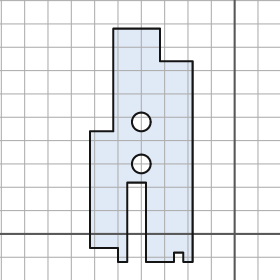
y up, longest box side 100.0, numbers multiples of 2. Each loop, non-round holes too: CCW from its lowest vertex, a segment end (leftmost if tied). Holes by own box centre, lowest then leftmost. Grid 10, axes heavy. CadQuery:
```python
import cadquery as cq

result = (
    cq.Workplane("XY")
    .moveTo(-50.0, -12.0)
    .lineTo(-46.0, -12.0)
    .lineTo(-46.0, 22.0)
    .lineTo(-38.0, 22.0)
    .lineTo(-38.0, -12.0)
    .lineTo(-26.0, -12.0)
    .lineTo(-26.0, -8.0)
    .lineTo(-22.0, -8.0)
    .lineTo(-22.0, -12.0)
    .lineTo(-18.0, -12.0)
    .lineTo(-18.0, 74.0)
    .lineTo(-32.0, 74.0)
    .lineTo(-32.0, 88.0)
    .lineTo(-52.0, 88.0)
    .lineTo(-52.0, 44.0)
    .lineTo(-62.0, 44.0)
    .lineTo(-62.0, -6.0)
    .lineTo(-50.0, -6.0)
    .close()
    .moveTo(-40.0, 30.0)
    .circle(4.0)
    .moveTo(-40.0, 48.0)
    .circle(4.0)
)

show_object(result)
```